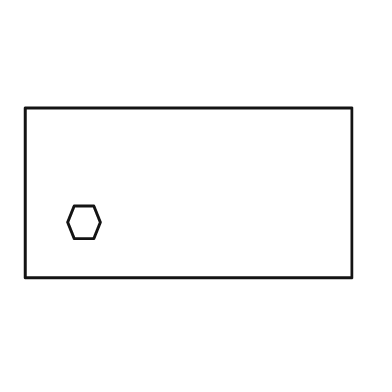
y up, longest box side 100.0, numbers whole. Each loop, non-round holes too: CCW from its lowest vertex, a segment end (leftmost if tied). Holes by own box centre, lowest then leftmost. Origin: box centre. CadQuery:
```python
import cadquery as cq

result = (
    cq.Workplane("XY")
    .moveTo(-50.0, -26.0)
    .lineTo(50.0, -26.0)
    .lineTo(50.0, 26.0)
    .lineTo(-50.0, 26.0)
    .close()
    .moveTo(-35.0, -14.0)
    .lineTo(-29.0, -14.0)
    .lineTo(-27.0, -9.0)
    .lineTo(-29.0, -4.0)
    .lineTo(-35.0, -4.0)
    .lineTo(-37.0, -9.0)
    .close()
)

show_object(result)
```